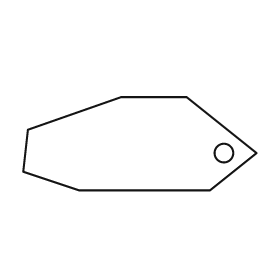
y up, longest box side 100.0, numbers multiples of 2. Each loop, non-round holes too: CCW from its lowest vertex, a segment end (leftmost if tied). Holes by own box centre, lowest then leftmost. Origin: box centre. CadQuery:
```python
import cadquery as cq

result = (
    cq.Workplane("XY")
    .moveTo(-26.0, -20.0)
    .lineTo(30.0, -20.0)
    .lineTo(50.0, -4.0)
    .lineTo(20.0, 20.0)
    .lineTo(-8.0, 20.0)
    .lineTo(-48.0, 6.0)
    .lineTo(-50.0, -12.0)
    .close()
    .moveTo(36.0, -4.0)
    .circle(4.0)
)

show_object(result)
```